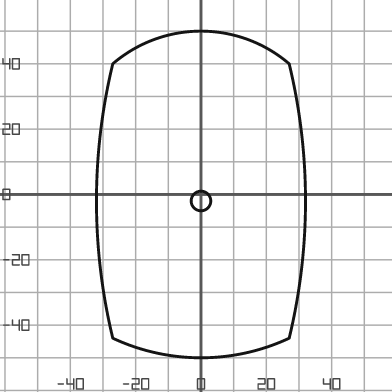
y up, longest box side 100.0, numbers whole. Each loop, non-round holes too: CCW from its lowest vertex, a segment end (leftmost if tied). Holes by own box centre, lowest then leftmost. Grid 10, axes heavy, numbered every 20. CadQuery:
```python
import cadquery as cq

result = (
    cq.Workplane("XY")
    .moveTo(-27.0, -44.0)
    .threePointArc((0.0, -50.0), (27.0, -44.0))
    .threePointArc((32.0, -2.0), (27.0, 40.0))
    .threePointArc((0.0, 50.0), (-27.0, 40.0))
    .threePointArc((-32.0, -2.0), (-27.0, -44.0))
    .close()
    .moveTo(0.0, -2.0)
    .circle(3.0)
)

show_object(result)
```